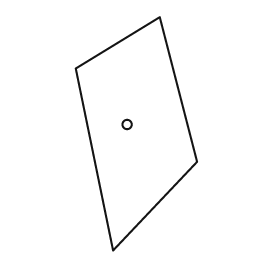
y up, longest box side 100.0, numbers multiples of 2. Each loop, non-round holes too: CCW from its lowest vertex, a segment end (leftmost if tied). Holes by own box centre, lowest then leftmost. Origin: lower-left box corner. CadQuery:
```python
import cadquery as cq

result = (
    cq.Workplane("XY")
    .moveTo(16.0, 0.0)
    .lineTo(52.0, 38.0)
    .lineTo(36.0, 100.0)
    .lineTo(0.0, 78.0)
    .close()
    .moveTo(22.0, 54.0)
    .circle(2.0)
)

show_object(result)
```